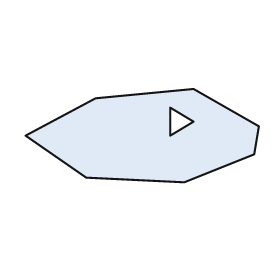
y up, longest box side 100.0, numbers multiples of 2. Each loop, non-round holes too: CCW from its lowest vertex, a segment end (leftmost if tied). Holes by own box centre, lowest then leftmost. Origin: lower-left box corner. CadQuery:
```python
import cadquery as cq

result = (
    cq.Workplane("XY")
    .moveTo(68.0, 0.0)
    .lineTo(98.0, 12.0)
    .lineTo(100.0, 24.0)
    .lineTo(72.0, 40.0)
    .lineTo(30.0, 36.0)
    .lineTo(0.0, 20.0)
    .lineTo(26.0, 2.0)
    .close()
    .moveTo(62.0, 20.0)
    .lineTo(72.0, 26.0)
    .lineTo(62.0, 32.0)
    .close()
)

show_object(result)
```